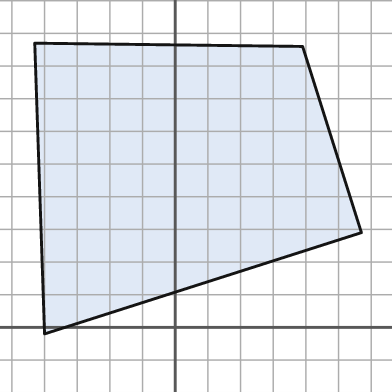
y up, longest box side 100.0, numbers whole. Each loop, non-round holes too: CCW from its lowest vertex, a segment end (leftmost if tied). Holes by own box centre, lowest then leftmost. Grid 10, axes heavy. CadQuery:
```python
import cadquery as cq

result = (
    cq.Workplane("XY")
    .moveTo(-40.0, -2.0)
    .lineTo(57.0, 29.0)
    .lineTo(39.0, 86.0)
    .lineTo(-43.0, 87.0)
    .close()
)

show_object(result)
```